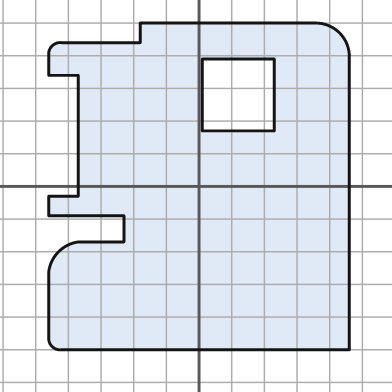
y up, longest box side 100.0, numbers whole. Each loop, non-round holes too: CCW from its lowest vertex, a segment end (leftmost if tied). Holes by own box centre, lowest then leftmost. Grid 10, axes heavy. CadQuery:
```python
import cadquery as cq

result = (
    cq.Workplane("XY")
    .moveTo(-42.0, -50.0)
    .lineTo(46.0, -50.0)
    .lineTo(46.0, 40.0)
    .threePointArc((43.0, 47.0), (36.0, 50.0))
    .lineTo(-18.0, 50.0)
    .lineTo(-18.0, 44.0)
    .lineTo(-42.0, 44.0)
    .threePointArc((-45.0, 43.0), (-46.0, 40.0))
    .lineTo(-46.0, 34.0)
    .lineTo(-37.0, 34.0)
    .lineTo(-37.0, -3.0)
    .lineTo(-46.0, -3.0)
    .lineTo(-46.0, -9.0)
    .lineTo(-23.0, -9.0)
    .lineTo(-23.0, -17.0)
    .lineTo(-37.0, -17.0)
    .threePointArc((-43.0, -20.0), (-46.0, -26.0))
    .lineTo(-46.0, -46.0)
    .threePointArc((-45.0, -49.0), (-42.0, -50.0))
    .close()
    .moveTo(1.0, 17.0)
    .lineTo(23.0, 17.0)
    .lineTo(23.0, 39.0)
    .lineTo(1.0, 39.0)
    .close()
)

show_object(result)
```